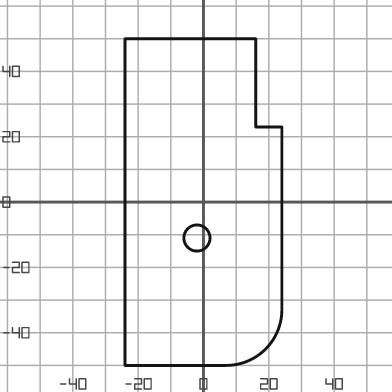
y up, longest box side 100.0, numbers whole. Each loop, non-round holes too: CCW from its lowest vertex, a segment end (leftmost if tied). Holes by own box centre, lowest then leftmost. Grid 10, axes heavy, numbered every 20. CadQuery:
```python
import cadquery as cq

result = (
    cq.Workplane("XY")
    .moveTo(-24.0, -50.0)
    .lineTo(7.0, -50.0)
    .threePointArc((19.0, -45.0), (24.0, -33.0))
    .lineTo(24.0, 23.0)
    .lineTo(16.0, 23.0)
    .lineTo(16.0, 50.0)
    .lineTo(-24.0, 50.0)
    .close()
    .moveTo(-2.0, -11.0)
    .circle(4.0)
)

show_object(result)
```